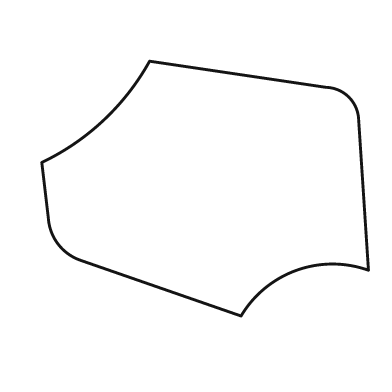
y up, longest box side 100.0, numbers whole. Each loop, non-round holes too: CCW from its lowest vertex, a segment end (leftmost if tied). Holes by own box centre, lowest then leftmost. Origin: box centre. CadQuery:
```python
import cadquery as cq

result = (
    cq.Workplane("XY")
    .moveTo(11.0, -39.0)
    .threePointArc((28.0, -25.0), (50.0, -25.0))
    .lineTo(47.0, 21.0)
    .threePointArc((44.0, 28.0), (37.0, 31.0))
    .lineTo(-17.0, 39.0)
    .threePointArc((-31.0, 21.0), (-50.0, 8.0))
    .lineTo(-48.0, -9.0)
    .threePointArc((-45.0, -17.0), (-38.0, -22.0))
    .close()
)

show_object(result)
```